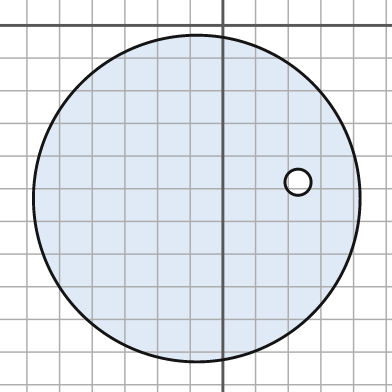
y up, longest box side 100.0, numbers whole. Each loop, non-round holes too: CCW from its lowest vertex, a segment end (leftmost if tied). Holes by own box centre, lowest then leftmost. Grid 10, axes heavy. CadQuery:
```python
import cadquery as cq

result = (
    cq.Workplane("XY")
    .moveTo(-8.0, -53.0)
    .circle(50.0)
    .moveTo(23.0, -48.0)
    .circle(4.0)
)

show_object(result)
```